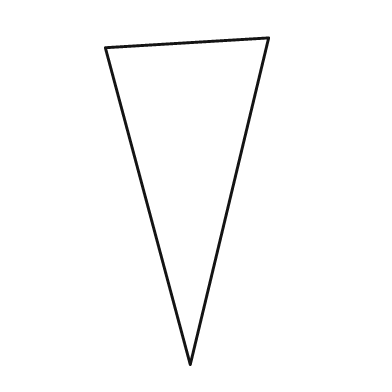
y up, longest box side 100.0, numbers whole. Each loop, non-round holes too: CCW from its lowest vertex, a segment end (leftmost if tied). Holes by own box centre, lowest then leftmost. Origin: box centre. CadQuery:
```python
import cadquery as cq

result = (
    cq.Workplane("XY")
    .moveTo(1.0, -50.0)
    .lineTo(25.0, 50.0)
    .lineTo(-25.0, 47.0)
    .close()
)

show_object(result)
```